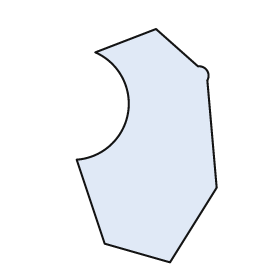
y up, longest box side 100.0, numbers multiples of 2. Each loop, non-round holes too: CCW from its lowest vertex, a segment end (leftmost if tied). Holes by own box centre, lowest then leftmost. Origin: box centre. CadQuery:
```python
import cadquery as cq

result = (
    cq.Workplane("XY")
    .moveTo(10.0, -50.0)
    .lineTo(30.0, -18.0)
    .lineTo(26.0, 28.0)
    .threePointArc((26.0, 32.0), (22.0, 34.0))
    .lineTo(4.0, 50.0)
    .lineTo(-22.0, 40.0)
    .threePointArc((-8.0, 14.0), (-30.0, -6.0))
    .lineTo(-18.0, -42.0)
    .close()
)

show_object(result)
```